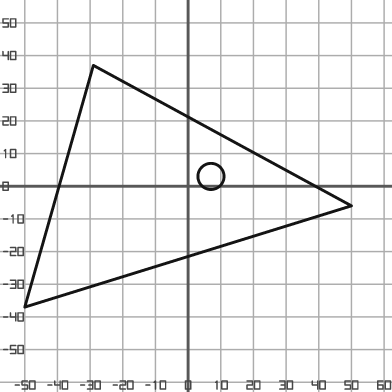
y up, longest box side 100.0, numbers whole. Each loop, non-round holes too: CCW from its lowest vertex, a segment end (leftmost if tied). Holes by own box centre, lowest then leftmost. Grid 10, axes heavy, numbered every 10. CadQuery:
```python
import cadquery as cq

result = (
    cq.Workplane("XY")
    .moveTo(-50.0, -37.0)
    .lineTo(50.0, -6.0)
    .lineTo(-29.0, 37.0)
    .close()
    .moveTo(7.0, 3.0)
    .circle(4.0)
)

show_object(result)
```